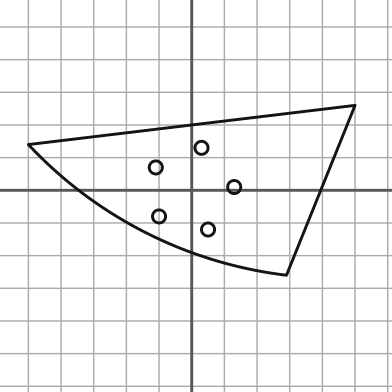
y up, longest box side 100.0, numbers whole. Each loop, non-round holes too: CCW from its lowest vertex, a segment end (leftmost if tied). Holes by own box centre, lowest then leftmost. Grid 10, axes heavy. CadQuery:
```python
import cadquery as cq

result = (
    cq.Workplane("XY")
    .moveTo(29.0, -26.0)
    .lineTo(50.0, 26.0)
    .lineTo(-50.0, 14.0)
    .threePointArc((-14.0, -13.0), (29.0, -26.0))
    .close()
    .moveTo(5.0, -12.0)
    .circle(2.0)
    .moveTo(-10.0, -8.0)
    .circle(2.0)
    .moveTo(13.0, 1.0)
    .circle(2.0)
    .moveTo(-11.0, 7.0)
    .circle(2.0)
    .moveTo(3.0, 13.0)
    .circle(2.0)
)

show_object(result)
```